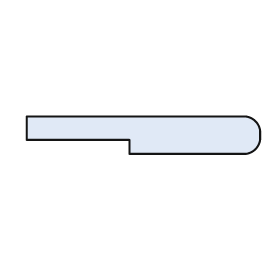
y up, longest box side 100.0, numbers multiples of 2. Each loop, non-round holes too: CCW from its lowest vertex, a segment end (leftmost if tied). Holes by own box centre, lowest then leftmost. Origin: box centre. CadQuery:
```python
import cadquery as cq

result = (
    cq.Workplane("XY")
    .moveTo(-6.0, -8.0)
    .lineTo(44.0, -8.0)
    .threePointArc((48.0, -6.0), (50.0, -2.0))
    .lineTo(50.0, 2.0)
    .threePointArc((48.0, 6.0), (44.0, 8.0))
    .lineTo(-50.0, 8.0)
    .lineTo(-50.0, -2.0)
    .lineTo(-6.0, -2.0)
    .close()
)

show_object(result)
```